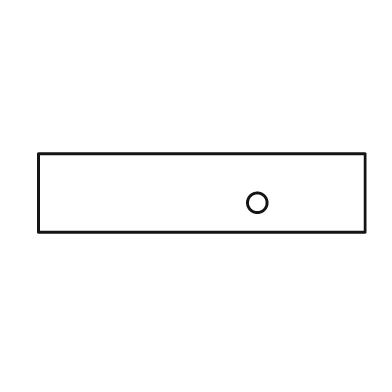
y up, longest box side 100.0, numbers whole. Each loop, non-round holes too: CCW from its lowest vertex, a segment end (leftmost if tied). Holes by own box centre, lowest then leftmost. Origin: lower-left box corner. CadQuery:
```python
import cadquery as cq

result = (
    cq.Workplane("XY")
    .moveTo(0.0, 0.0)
    .lineTo(100.0, 0.0)
    .lineTo(100.0, 24.0)
    .lineTo(0.0, 24.0)
    .close()
    .moveTo(67.0, 9.0)
    .circle(3.0)
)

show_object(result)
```